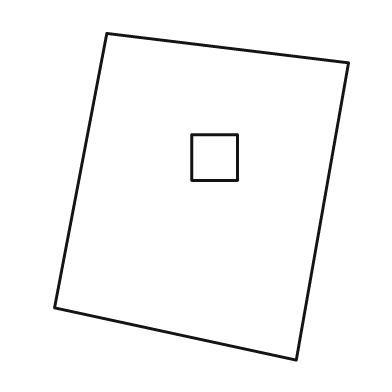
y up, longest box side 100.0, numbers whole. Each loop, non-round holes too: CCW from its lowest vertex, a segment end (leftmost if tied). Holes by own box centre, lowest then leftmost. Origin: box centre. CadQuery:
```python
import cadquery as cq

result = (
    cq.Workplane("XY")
    .moveTo(29.0, -50.0)
    .lineTo(45.0, 41.0)
    .lineTo(-29.0, 50.0)
    .lineTo(-45.0, -34.0)
    .close()
    .moveTo(-3.0, 5.0)
    .lineTo(11.0, 5.0)
    .lineTo(11.0, 19.0)
    .lineTo(-3.0, 19.0)
    .close()
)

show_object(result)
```